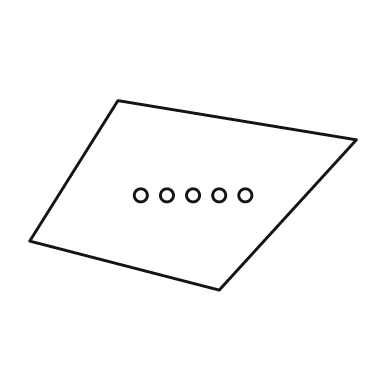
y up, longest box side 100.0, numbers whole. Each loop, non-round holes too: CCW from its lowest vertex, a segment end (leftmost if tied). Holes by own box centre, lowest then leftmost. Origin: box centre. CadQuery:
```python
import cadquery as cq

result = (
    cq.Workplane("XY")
    .moveTo(8.0, -29.0)
    .lineTo(50.0, 17.0)
    .lineTo(-23.0, 29.0)
    .lineTo(-50.0, -14.0)
    .close()
    .moveTo(-16.0, 0.0)
    .circle(2.0)
    .moveTo(-8.0, 0.0)
    .circle(2.0)
    .moveTo(0.0, 0.0)
    .circle(2.0)
    .moveTo(8.0, 0.0)
    .circle(2.0)
    .moveTo(16.0, 0.0)
    .circle(2.0)
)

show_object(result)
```